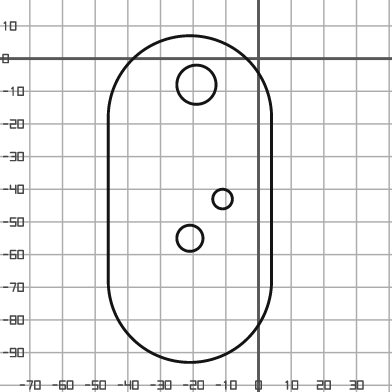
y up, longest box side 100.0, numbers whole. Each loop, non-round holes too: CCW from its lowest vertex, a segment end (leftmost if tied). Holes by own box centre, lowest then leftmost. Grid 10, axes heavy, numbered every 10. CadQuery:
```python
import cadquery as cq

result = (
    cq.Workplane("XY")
    .moveTo(-46.0, -68.0)
    .threePointArc((-21.0, -93.0), (4.0, -68.0))
    .lineTo(4.0, -18.0)
    .threePointArc((-21.0, 7.0), (-46.0, -18.0))
    .close()
    .moveTo(-21.0, -55.0)
    .circle(4.0)
    .moveTo(-11.0, -43.0)
    .circle(3.0)
    .moveTo(-19.0, -8.0)
    .circle(6.0)
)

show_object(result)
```